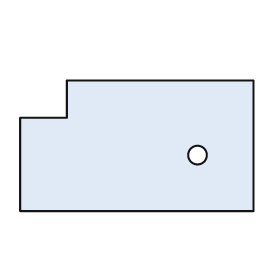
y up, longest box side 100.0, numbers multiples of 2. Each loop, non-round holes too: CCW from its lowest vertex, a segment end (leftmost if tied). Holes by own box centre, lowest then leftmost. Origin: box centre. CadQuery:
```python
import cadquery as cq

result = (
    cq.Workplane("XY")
    .moveTo(-50.0, -28.0)
    .lineTo(50.0, -28.0)
    .lineTo(50.0, 28.0)
    .lineTo(-30.0, 28.0)
    .lineTo(-30.0, 12.0)
    .lineTo(-50.0, 12.0)
    .close()
    .moveTo(26.0, -4.0)
    .circle(4.0)
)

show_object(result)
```